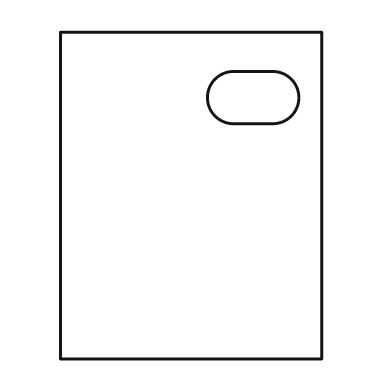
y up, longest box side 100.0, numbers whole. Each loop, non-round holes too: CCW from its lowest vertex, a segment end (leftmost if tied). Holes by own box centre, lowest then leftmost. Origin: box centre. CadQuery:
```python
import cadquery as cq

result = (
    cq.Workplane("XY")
    .moveTo(-40.0, -50.0)
    .lineTo(40.0, -50.0)
    .lineTo(40.0, 50.0)
    .lineTo(-40.0, 50.0)
    .close()
    .moveTo(13.0, 22.0)
    .lineTo(25.0, 22.0)
    .threePointArc((33.0, 30.0), (25.0, 38.0))
    .lineTo(13.0, 38.0)
    .threePointArc((5.0, 30.0), (13.0, 22.0))
    .close()
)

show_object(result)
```